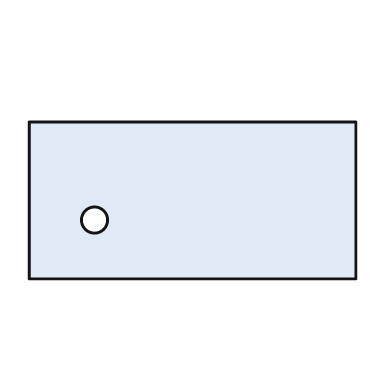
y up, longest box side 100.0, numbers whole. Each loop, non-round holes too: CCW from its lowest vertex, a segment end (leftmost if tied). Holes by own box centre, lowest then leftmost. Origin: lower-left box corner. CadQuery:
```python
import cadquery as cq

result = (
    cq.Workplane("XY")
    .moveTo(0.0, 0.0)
    .lineTo(100.0, 0.0)
    .lineTo(100.0, 48.0)
    .lineTo(0.0, 48.0)
    .close()
    .moveTo(20.0, 18.0)
    .circle(4.0)
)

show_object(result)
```